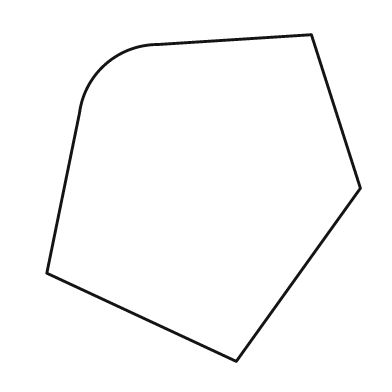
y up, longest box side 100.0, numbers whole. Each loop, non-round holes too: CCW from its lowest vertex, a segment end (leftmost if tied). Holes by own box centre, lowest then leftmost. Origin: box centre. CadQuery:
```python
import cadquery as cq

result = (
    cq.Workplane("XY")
    .moveTo(10.0, -50.0)
    .lineTo(48.0, 3.0)
    .lineTo(33.0, 50.0)
    .lineTo(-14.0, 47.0)
    .threePointArc((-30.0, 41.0), (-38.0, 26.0))
    .lineTo(-48.0, -23.0)
    .close()
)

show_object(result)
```